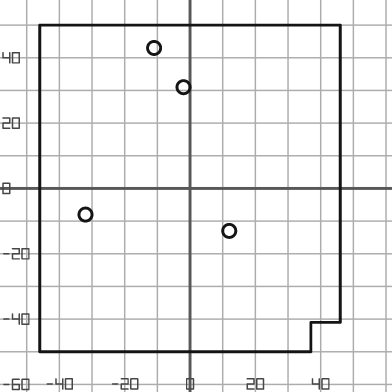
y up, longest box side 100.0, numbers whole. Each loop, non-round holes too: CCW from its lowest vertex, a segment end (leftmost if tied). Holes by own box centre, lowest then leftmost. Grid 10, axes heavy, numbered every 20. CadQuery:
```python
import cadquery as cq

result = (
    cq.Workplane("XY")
    .moveTo(-46.0, -50.0)
    .lineTo(37.0, -50.0)
    .lineTo(37.0, -41.0)
    .lineTo(46.0, -41.0)
    .lineTo(46.0, 50.0)
    .lineTo(-46.0, 50.0)
    .close()
    .moveTo(12.0, -13.0)
    .circle(2.0)
    .moveTo(-32.0, -8.0)
    .circle(2.0)
    .moveTo(-2.0, 31.0)
    .circle(2.0)
    .moveTo(-11.0, 43.0)
    .circle(2.0)
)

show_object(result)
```